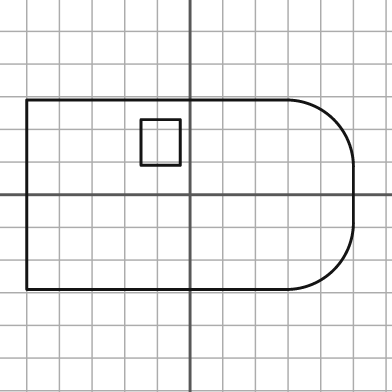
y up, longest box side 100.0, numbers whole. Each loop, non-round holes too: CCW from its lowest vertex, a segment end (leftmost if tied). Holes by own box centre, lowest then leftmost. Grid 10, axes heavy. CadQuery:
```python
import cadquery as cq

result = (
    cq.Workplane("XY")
    .moveTo(-50.0, -29.0)
    .lineTo(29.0, -29.0)
    .threePointArc((44.0, -23.0), (50.0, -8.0))
    .lineTo(50.0, 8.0)
    .threePointArc((44.0, 23.0), (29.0, 29.0))
    .lineTo(-50.0, 29.0)
    .close()
    .moveTo(-15.0, 9.0)
    .lineTo(-3.0, 9.0)
    .lineTo(-3.0, 23.0)
    .lineTo(-15.0, 23.0)
    .close()
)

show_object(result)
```